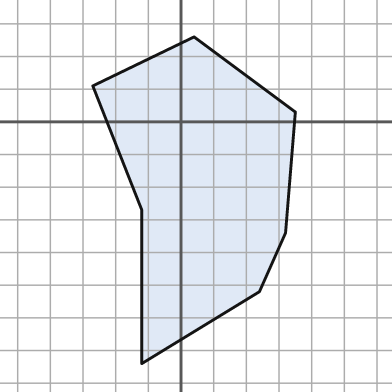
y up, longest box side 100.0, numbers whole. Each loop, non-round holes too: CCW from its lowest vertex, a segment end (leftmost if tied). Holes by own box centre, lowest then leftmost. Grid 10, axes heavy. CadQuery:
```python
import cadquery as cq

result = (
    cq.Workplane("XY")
    .moveTo(-12.0, -74.0)
    .lineTo(24.0, -52.0)
    .lineTo(32.0, -34.0)
    .lineTo(35.0, 3.0)
    .lineTo(4.0, 26.0)
    .lineTo(-27.0, 11.0)
    .lineTo(-12.0, -27.0)
    .close()
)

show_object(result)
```